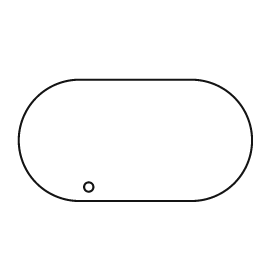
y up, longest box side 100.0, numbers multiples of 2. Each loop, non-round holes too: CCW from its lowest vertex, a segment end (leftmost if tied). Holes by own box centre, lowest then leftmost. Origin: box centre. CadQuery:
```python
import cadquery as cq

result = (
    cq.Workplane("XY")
    .moveTo(-24.0, -26.0)
    .lineTo(24.0, -26.0)
    .threePointArc((50.0, 0.0), (24.0, 26.0))
    .lineTo(-24.0, 26.0)
    .threePointArc((-50.0, 0.0), (-24.0, -26.0))
    .close()
    .moveTo(-20.0, -20.0)
    .circle(2.0)
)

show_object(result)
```